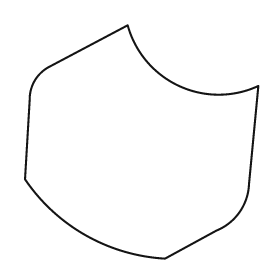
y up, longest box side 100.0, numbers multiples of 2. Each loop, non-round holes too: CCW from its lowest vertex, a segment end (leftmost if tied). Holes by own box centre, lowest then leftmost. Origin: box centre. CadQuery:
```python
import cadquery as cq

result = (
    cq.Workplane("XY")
    .moveTo(10.0, -50.0)
    .lineTo(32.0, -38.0)
    .threePointArc((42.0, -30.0), (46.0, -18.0))
    .lineTo(50.0, 24.0)
    .threePointArc((16.0, 24.0), (-6.0, 50.0))
    .lineTo(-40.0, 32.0)
    .threePointArc((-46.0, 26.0), (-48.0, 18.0))
    .lineTo(-50.0, -16.0)
    .threePointArc((-24.0, -40.0), (10.0, -50.0))
    .close()
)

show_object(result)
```